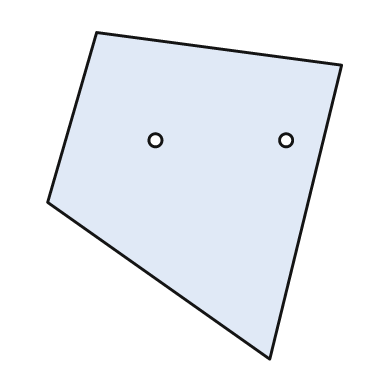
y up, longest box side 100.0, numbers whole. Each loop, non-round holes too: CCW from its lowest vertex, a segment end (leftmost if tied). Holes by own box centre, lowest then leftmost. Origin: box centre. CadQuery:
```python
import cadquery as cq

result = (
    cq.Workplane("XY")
    .moveTo(23.0, -50.0)
    .lineTo(45.0, 40.0)
    .lineTo(-30.0, 50.0)
    .lineTo(-45.0, -2.0)
    .close()
    .moveTo(-12.0, 17.0)
    .circle(2.0)
    .moveTo(28.0, 17.0)
    .circle(2.0)
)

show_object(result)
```